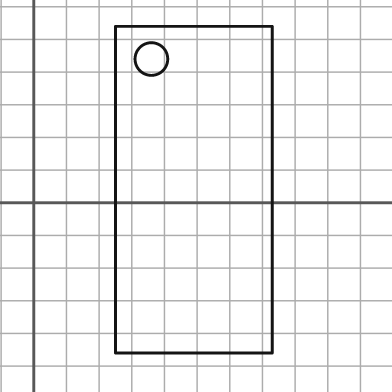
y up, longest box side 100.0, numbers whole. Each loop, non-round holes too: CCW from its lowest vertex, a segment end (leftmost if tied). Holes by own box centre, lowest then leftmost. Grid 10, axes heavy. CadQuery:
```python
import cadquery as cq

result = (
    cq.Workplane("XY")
    .moveTo(25.0, -46.0)
    .lineTo(73.0, -46.0)
    .lineTo(73.0, 54.0)
    .lineTo(25.0, 54.0)
    .close()
    .moveTo(36.0, 44.0)
    .circle(5.0)
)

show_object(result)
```